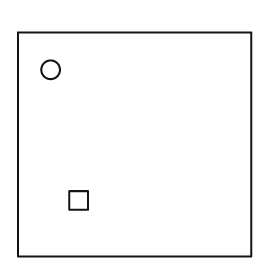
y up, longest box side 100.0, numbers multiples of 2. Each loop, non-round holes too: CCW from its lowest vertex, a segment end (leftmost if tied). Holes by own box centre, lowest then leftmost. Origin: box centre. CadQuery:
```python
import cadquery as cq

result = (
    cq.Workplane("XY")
    .moveTo(-50.0, -48.0)
    .lineTo(50.0, -48.0)
    .lineTo(50.0, 48.0)
    .lineTo(-50.0, 48.0)
    .close()
    .moveTo(-28.0, -28.0)
    .lineTo(-20.0, -28.0)
    .lineTo(-20.0, -20.0)
    .lineTo(-28.0, -20.0)
    .close()
    .moveTo(-36.0, 32.0)
    .circle(4.0)
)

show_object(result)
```